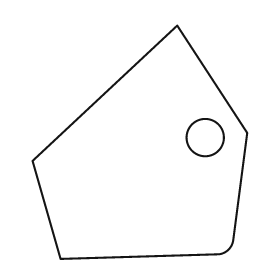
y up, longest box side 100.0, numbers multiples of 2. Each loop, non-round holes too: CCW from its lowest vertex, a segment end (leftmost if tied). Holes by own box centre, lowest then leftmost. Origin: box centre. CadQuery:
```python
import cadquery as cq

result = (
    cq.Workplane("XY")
    .moveTo(-34.0, -50.0)
    .lineTo(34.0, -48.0)
    .threePointArc((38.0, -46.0), (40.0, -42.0))
    .lineTo(46.0, 4.0)
    .lineTo(16.0, 50.0)
    .lineTo(-46.0, -8.0)
    .close()
    .moveTo(28.0, 2.0)
    .circle(8.0)
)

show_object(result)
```